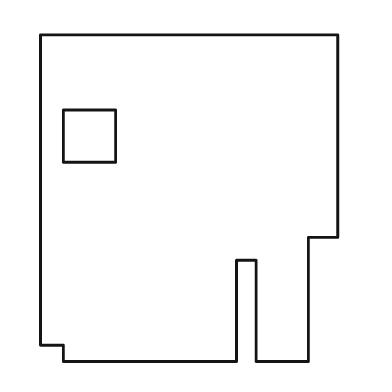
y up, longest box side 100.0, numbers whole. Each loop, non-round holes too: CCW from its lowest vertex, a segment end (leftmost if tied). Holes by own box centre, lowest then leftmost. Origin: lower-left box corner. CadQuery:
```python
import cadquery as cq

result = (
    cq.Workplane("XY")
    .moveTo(7.0, 0.0)
    .lineTo(60.0, 0.0)
    .lineTo(60.0, 31.0)
    .lineTo(66.0, 31.0)
    .lineTo(66.0, 0.0)
    .lineTo(82.0, 0.0)
    .lineTo(82.0, 38.0)
    .lineTo(91.0, 38.0)
    .lineTo(91.0, 100.0)
    .lineTo(0.0, 100.0)
    .lineTo(0.0, 5.0)
    .lineTo(7.0, 5.0)
    .close()
    .moveTo(7.0, 61.0)
    .lineTo(23.0, 61.0)
    .lineTo(23.0, 77.0)
    .lineTo(7.0, 77.0)
    .close()
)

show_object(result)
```